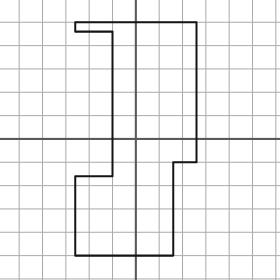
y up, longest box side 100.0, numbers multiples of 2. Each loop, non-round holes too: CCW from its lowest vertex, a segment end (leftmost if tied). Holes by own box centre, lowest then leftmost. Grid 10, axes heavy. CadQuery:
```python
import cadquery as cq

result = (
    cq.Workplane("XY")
    .moveTo(-26.0, -50.0)
    .lineTo(16.0, -50.0)
    .lineTo(16.0, -10.0)
    .lineTo(26.0, -10.0)
    .lineTo(26.0, 50.0)
    .lineTo(-26.0, 50.0)
    .lineTo(-26.0, 46.0)
    .lineTo(-10.0, 46.0)
    .lineTo(-10.0, -16.0)
    .lineTo(-26.0, -16.0)
    .close()
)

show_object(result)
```